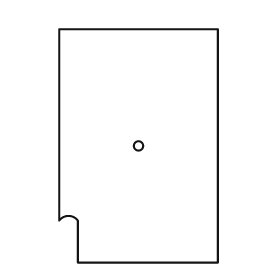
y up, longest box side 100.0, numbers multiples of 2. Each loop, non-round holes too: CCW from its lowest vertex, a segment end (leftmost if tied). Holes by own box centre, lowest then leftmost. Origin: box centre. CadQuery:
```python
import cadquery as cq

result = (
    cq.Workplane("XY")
    .moveTo(-26.0, -50.0)
    .lineTo(34.0, -50.0)
    .lineTo(34.0, 50.0)
    .lineTo(-34.0, 50.0)
    .lineTo(-34.0, -32.0)
    .threePointArc((-30.0, -30.0), (-26.0, -32.0))
    .close()
    .moveTo(0.0, 0.0)
    .circle(2.0)
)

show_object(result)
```